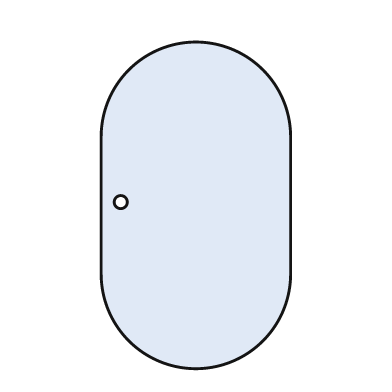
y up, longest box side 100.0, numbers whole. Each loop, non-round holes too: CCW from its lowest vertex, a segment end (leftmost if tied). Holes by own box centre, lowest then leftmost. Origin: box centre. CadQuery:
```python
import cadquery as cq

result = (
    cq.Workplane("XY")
    .moveTo(-29.0, -21.0)
    .threePointArc((0.0, -50.0), (29.0, -21.0))
    .lineTo(29.0, 21.0)
    .threePointArc((0.0, 50.0), (-29.0, 21.0))
    .close()
    .moveTo(-23.0, 1.0)
    .circle(2.0)
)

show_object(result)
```